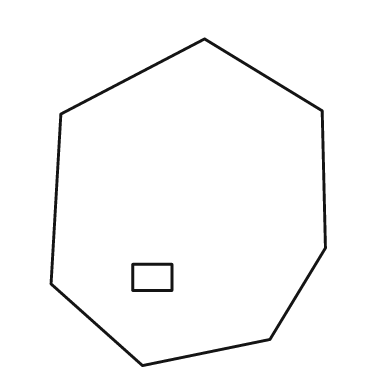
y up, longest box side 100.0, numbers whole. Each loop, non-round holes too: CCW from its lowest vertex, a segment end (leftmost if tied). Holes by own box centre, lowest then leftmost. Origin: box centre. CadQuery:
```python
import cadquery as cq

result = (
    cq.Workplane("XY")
    .moveTo(-14.0, -50.0)
    .lineTo(25.0, -42.0)
    .lineTo(42.0, -14.0)
    .lineTo(41.0, 28.0)
    .lineTo(5.0, 50.0)
    .lineTo(-39.0, 27.0)
    .lineTo(-42.0, -25.0)
    .close()
    .moveTo(-17.0, -27.0)
    .lineTo(-5.0, -27.0)
    .lineTo(-5.0, -19.0)
    .lineTo(-17.0, -19.0)
    .close()
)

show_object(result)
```